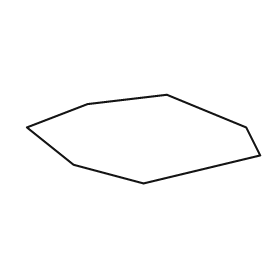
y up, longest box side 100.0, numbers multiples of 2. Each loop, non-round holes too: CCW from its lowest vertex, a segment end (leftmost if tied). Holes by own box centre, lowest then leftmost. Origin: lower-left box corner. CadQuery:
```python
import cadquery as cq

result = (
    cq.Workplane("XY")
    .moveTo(50.0, 0.0)
    .lineTo(100.0, 12.0)
    .lineTo(94.0, 24.0)
    .lineTo(60.0, 38.0)
    .lineTo(26.0, 34.0)
    .lineTo(0.0, 24.0)
    .lineTo(20.0, 8.0)
    .close()
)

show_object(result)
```